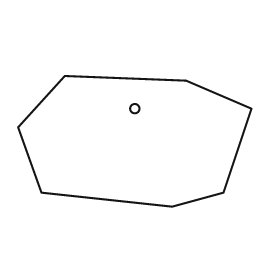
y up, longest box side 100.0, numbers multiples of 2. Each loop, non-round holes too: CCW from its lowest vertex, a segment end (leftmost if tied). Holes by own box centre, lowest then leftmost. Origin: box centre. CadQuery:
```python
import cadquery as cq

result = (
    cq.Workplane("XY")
    .moveTo(16.0, -28.0)
    .lineTo(38.0, -22.0)
    .lineTo(50.0, 14.0)
    .lineTo(22.0, 26.0)
    .lineTo(-30.0, 28.0)
    .lineTo(-50.0, 6.0)
    .lineTo(-40.0, -22.0)
    .close()
    .moveTo(0.0, 14.0)
    .circle(2.0)
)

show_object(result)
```